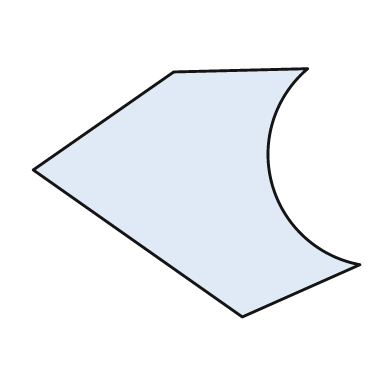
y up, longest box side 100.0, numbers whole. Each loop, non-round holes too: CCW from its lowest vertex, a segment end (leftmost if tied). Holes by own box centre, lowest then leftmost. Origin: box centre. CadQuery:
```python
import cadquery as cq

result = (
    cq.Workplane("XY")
    .moveTo(14.0, -38.0)
    .lineTo(50.0, -22.0)
    .threePointArc((23.0, 3.0), (34.0, 38.0))
    .lineTo(-7.0, 37.0)
    .lineTo(-50.0, 7.0)
    .close()
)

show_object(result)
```